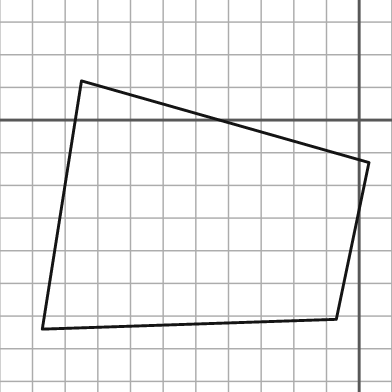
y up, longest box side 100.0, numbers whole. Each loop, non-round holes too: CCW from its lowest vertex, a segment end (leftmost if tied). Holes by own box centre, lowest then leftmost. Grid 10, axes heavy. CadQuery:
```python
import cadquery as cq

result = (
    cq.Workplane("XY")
    .moveTo(-97.0, -64.0)
    .lineTo(-7.0, -61.0)
    .lineTo(3.0, -13.0)
    .lineTo(-85.0, 12.0)
    .close()
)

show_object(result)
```